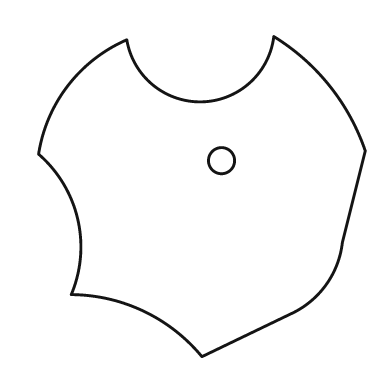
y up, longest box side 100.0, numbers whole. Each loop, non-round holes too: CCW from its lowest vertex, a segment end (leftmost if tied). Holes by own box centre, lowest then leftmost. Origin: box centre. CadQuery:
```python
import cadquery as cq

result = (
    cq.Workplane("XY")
    .moveTo(0.0, -49.0)
    .lineTo(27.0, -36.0)
    .threePointArc((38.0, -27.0), (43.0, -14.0))
    .lineTo(50.0, 14.0)
    .threePointArc((39.0, 34.0), (22.0, 49.0))
    .threePointArc((0.0, 29.0), (-23.0, 48.0))
    .threePointArc((-41.0, 34.0), (-50.0, 13.0))
    .threePointArc((-38.0, -7.0), (-40.0, -30.0))
    .threePointArc((-18.0, -35.0), (0.0, -49.0))
    .close()
    .moveTo(6.0, 11.0)
    .circle(4.0)
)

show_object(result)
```